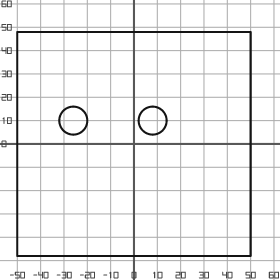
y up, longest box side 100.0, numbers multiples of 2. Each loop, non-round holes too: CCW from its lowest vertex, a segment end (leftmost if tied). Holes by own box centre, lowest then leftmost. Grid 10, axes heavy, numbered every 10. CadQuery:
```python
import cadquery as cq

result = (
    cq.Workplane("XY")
    .moveTo(-50.0, -48.0)
    .lineTo(50.0, -48.0)
    .lineTo(50.0, 48.0)
    .lineTo(-50.0, 48.0)
    .close()
    .moveTo(-26.0, 10.0)
    .circle(6.0)
    .moveTo(8.0, 10.0)
    .circle(6.0)
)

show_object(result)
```